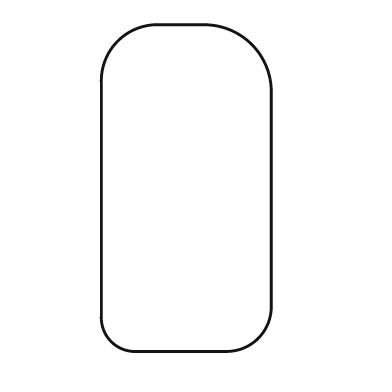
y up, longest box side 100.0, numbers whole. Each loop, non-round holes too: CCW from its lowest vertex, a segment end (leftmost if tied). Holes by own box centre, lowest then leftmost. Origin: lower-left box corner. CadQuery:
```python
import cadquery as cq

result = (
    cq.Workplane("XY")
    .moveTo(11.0, 0.0)
    .lineTo(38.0, 0.0)
    .threePointArc((48.0, 4.0), (52.0, 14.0))
    .lineTo(52.0, 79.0)
    .threePointArc((46.0, 94.0), (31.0, 100.0))
    .lineTo(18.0, 100.0)
    .threePointArc((5.0, 95.0), (0.0, 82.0))
    .lineTo(0.0, 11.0)
    .threePointArc((3.0, 3.0), (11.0, 0.0))
    .close()
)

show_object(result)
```